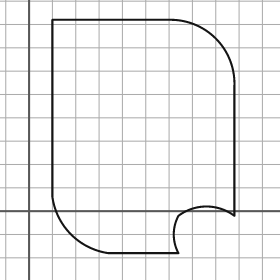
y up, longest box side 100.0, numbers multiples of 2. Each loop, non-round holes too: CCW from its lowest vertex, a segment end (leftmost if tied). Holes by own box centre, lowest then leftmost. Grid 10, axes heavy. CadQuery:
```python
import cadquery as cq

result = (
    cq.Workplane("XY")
    .moveTo(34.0, -18.0)
    .lineTo(64.0, -18.0)
    .threePointArc((62.0, -10.0), (64.0, -2.0))
    .threePointArc((76.0, 2.0), (88.0, -2.0))
    .lineTo(88.0, 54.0)
    .threePointArc((80.0, 74.0), (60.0, 82.0))
    .lineTo(10.0, 82.0)
    .lineTo(10.0, 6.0)
    .threePointArc((18.0, -10.0), (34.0, -18.0))
    .close()
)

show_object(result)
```